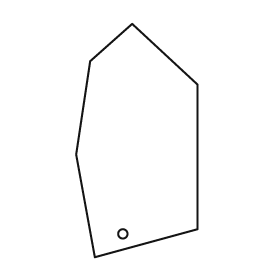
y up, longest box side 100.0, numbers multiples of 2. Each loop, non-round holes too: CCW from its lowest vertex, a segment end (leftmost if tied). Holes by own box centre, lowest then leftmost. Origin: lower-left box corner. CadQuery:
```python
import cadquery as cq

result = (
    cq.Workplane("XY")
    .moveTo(8.0, 0.0)
    .lineTo(52.0, 12.0)
    .lineTo(52.0, 74.0)
    .lineTo(24.0, 100.0)
    .lineTo(6.0, 84.0)
    .lineTo(0.0, 44.0)
    .close()
    .moveTo(20.0, 10.0)
    .circle(2.0)
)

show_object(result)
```